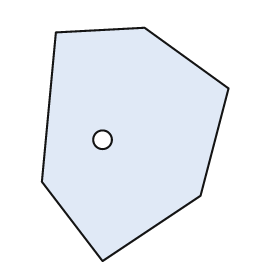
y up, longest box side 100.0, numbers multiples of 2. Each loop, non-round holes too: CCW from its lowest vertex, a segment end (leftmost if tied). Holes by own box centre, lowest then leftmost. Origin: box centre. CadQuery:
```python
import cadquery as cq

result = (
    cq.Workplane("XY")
    .moveTo(-14.0, -50.0)
    .lineTo(28.0, -22.0)
    .lineTo(40.0, 24.0)
    .lineTo(4.0, 50.0)
    .lineTo(-34.0, 48.0)
    .lineTo(-40.0, -16.0)
    .close()
    .moveTo(-14.0, 2.0)
    .circle(4.0)
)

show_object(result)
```